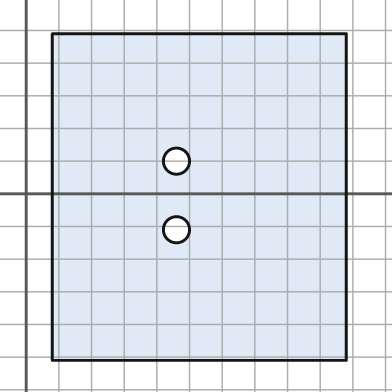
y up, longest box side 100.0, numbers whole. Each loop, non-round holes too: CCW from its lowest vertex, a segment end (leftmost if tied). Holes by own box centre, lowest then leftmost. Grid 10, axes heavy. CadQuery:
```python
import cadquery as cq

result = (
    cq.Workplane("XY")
    .moveTo(8.0, -51.0)
    .lineTo(98.0, -51.0)
    .lineTo(98.0, 49.0)
    .lineTo(8.0, 49.0)
    .close()
    .moveTo(46.0, -11.0)
    .circle(4.0)
    .moveTo(46.0, 10.0)
    .circle(4.0)
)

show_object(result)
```